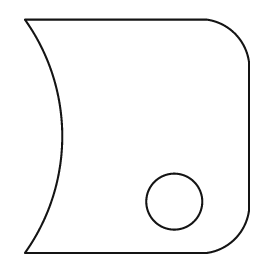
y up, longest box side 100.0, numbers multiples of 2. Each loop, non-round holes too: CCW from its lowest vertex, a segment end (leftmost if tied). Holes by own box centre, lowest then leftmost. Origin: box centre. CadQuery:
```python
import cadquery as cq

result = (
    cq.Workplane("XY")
    .moveTo(-48.0, -50.0)
    .lineTo(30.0, -50.0)
    .threePointArc((42.0, -44.0), (48.0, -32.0))
    .lineTo(48.0, 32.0)
    .threePointArc((42.0, 44.0), (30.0, 50.0))
    .lineTo(-48.0, 50.0)
    .threePointArc((-32.0, 0.0), (-48.0, -50.0))
    .close()
    .moveTo(16.0, -28.0)
    .circle(12.0)
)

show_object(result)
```